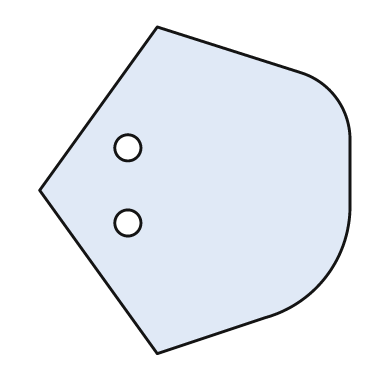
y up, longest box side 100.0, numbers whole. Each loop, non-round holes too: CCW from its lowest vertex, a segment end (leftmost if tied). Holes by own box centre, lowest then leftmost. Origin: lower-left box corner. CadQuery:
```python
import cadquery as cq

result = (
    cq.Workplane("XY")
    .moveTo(36.0, 0.0)
    .lineTo(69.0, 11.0)
    .threePointArc((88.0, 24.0), (95.0, 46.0))
    .lineTo(95.0, 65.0)
    .threePointArc((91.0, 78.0), (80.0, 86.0))
    .lineTo(36.0, 100.0)
    .lineTo(0.0, 50.0)
    .close()
    .moveTo(27.0, 40.0)
    .circle(4.0)
    .moveTo(27.0, 63.0)
    .circle(4.0)
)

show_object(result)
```